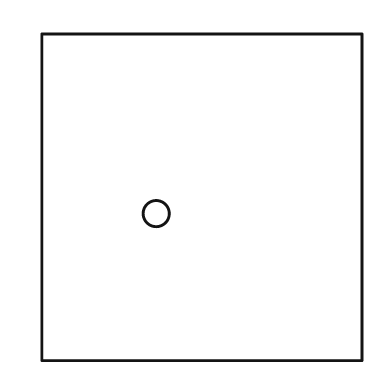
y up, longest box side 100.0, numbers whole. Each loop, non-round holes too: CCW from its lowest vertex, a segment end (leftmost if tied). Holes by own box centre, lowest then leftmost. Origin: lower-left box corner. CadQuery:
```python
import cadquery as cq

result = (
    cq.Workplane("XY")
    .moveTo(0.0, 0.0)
    .lineTo(98.0, 0.0)
    .lineTo(98.0, 100.0)
    .lineTo(0.0, 100.0)
    .close()
    .moveTo(35.0, 45.0)
    .circle(4.0)
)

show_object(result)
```